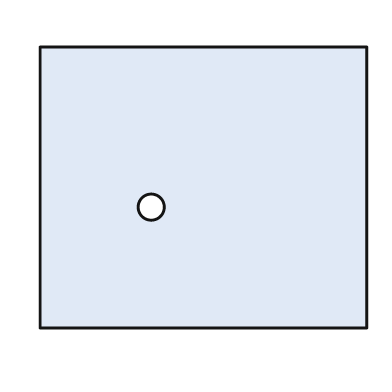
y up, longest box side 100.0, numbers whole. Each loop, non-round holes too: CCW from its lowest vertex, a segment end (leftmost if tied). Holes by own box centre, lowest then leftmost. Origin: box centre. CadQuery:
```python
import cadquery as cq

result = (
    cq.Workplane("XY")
    .moveTo(-50.0, -43.0)
    .lineTo(50.0, -43.0)
    .lineTo(50.0, 43.0)
    .lineTo(-50.0, 43.0)
    .close()
    .moveTo(-16.0, -6.0)
    .circle(4.0)
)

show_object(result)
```